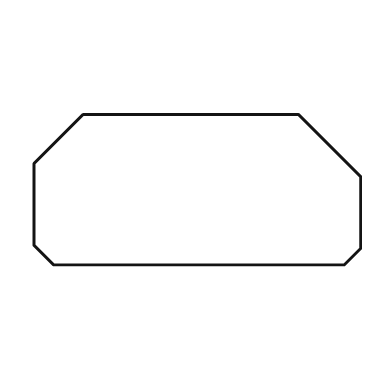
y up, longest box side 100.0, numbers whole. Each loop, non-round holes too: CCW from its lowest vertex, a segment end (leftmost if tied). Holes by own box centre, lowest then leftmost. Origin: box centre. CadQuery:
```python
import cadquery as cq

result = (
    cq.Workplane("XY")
    .moveTo(-44.0, -23.0)
    .lineTo(45.0, -23.0)
    .lineTo(50.0, -18.0)
    .lineTo(50.0, 4.0)
    .lineTo(31.0, 23.0)
    .lineTo(-35.0, 23.0)
    .lineTo(-50.0, 8.0)
    .lineTo(-50.0, -17.0)
    .close()
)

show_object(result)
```